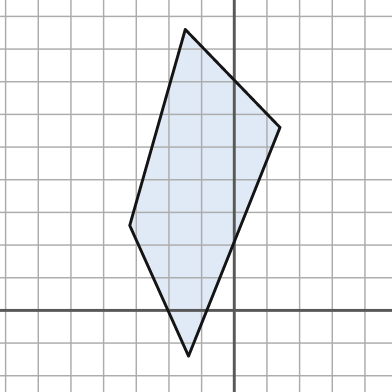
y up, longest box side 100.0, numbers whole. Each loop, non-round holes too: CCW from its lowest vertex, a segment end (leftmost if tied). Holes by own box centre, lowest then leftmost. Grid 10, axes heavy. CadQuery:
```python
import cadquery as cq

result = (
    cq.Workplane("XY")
    .moveTo(-14.0, -14.0)
    .lineTo(14.0, 56.0)
    .lineTo(-15.0, 86.0)
    .lineTo(-32.0, 26.0)
    .close()
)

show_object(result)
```